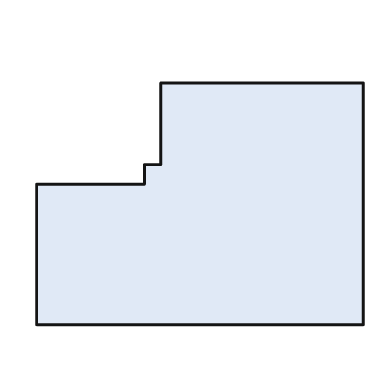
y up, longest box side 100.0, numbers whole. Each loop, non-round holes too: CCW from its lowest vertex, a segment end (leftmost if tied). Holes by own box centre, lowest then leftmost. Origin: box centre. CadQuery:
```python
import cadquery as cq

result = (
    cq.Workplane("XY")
    .moveTo(-50.0, -37.0)
    .lineTo(50.0, -37.0)
    .lineTo(50.0, 37.0)
    .lineTo(-12.0, 37.0)
    .lineTo(-12.0, 12.0)
    .lineTo(-17.0, 12.0)
    .lineTo(-17.0, 6.0)
    .lineTo(-50.0, 6.0)
    .close()
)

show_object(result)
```